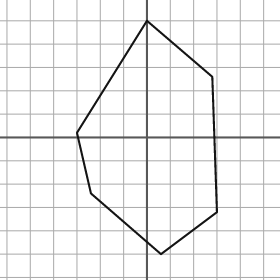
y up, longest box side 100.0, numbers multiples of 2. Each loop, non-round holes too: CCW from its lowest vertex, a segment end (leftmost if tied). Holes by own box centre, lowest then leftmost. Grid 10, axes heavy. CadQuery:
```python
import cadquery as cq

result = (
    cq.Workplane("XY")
    .moveTo(6.0, -50.0)
    .lineTo(30.0, -32.0)
    .lineTo(28.0, 26.0)
    .lineTo(0.0, 50.0)
    .lineTo(-30.0, 2.0)
    .lineTo(-24.0, -24.0)
    .close()
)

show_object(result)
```